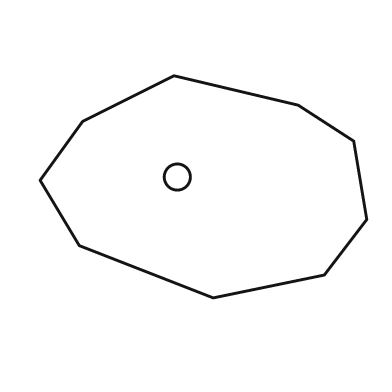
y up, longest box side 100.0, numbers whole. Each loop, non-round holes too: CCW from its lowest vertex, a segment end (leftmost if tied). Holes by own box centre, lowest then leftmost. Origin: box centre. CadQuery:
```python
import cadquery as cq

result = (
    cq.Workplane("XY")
    .moveTo(3.0, -34.0)
    .lineTo(37.0, -27.0)
    .lineTo(50.0, -10.0)
    .lineTo(46.0, 14.0)
    .lineTo(29.0, 25.0)
    .lineTo(-9.0, 34.0)
    .lineTo(-37.0, 20.0)
    .lineTo(-50.0, 2.0)
    .lineTo(-38.0, -18.0)
    .close()
    .moveTo(-8.0, 3.0)
    .circle(4.0)
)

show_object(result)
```